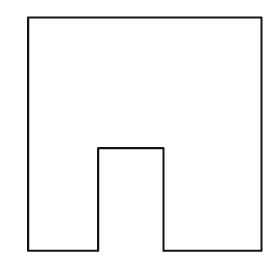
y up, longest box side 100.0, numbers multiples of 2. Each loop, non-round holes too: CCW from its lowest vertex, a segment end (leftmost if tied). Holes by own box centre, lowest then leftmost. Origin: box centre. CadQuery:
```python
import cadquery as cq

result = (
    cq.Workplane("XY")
    .moveTo(-50.0, -50.0)
    .lineTo(-20.0, -50.0)
    .lineTo(-20.0, -6.0)
    .lineTo(8.0, -6.0)
    .lineTo(8.0, -50.0)
    .lineTo(50.0, -50.0)
    .lineTo(50.0, 50.0)
    .lineTo(-50.0, 50.0)
    .close()
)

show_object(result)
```